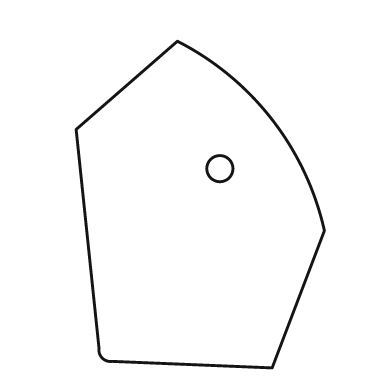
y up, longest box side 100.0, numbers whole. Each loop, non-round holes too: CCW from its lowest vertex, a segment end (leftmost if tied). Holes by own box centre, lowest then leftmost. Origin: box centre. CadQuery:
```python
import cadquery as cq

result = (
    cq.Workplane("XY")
    .moveTo(22.0, -50.0)
    .lineTo(38.0, -8.0)
    .threePointArc((22.0, 26.0), (-7.0, 50.0))
    .lineTo(-38.0, 23.0)
    .lineTo(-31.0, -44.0)
    .threePointArc((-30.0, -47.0), (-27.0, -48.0))
    .close()
    .moveTo(6.0, 11.0)
    .circle(4.0)
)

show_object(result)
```